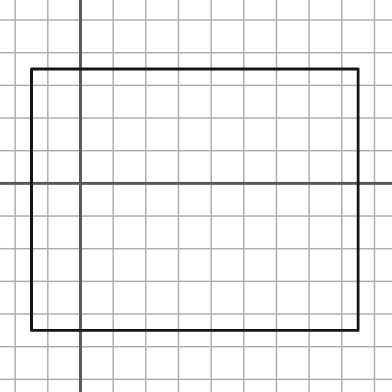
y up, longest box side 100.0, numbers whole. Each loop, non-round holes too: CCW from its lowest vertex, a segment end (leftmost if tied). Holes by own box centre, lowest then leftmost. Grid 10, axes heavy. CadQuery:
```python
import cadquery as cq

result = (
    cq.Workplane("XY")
    .moveTo(-15.0, -45.0)
    .lineTo(85.0, -45.0)
    .lineTo(85.0, 35.0)
    .lineTo(-15.0, 35.0)
    .close()
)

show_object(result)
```